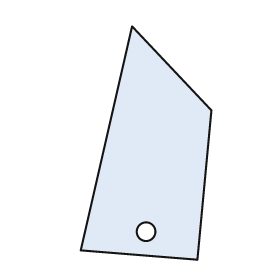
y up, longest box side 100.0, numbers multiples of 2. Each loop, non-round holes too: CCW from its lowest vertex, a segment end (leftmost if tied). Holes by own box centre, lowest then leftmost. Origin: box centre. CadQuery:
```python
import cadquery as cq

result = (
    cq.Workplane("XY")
    .moveTo(22.0, -50.0)
    .lineTo(28.0, 14.0)
    .lineTo(-6.0, 50.0)
    .lineTo(-28.0, -46.0)
    .close()
    .moveTo(0.0, -38.0)
    .circle(4.0)
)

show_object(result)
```